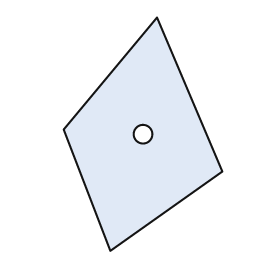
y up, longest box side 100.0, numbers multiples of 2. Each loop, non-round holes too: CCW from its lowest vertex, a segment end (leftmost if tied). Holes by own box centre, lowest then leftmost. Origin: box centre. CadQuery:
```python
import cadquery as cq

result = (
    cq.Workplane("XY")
    .moveTo(-14.0, -50.0)
    .lineTo(34.0, -16.0)
    .lineTo(6.0, 50.0)
    .lineTo(-34.0, 2.0)
    .close()
    .moveTo(0.0, 0.0)
    .circle(4.0)
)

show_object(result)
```